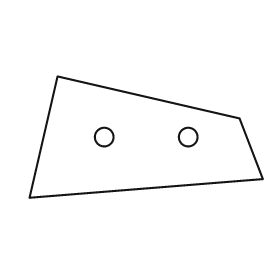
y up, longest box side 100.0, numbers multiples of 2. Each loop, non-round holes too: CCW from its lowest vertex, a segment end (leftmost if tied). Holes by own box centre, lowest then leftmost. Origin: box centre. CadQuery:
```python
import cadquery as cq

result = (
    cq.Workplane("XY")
    .moveTo(-50.0, -26.0)
    .lineTo(50.0, -18.0)
    .lineTo(40.0, 8.0)
    .lineTo(-38.0, 26.0)
    .close()
    .moveTo(-18.0, 0.0)
    .circle(4.0)
    .moveTo(18.0, 0.0)
    .circle(4.0)
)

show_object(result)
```